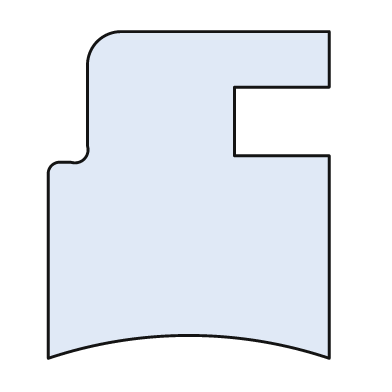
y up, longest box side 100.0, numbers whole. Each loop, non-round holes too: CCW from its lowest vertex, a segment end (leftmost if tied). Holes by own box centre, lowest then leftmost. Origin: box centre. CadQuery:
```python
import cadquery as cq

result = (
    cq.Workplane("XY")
    .moveTo(-43.0, -50.0)
    .threePointArc((0.0, -43.0), (43.0, -50.0))
    .lineTo(43.0, 12.0)
    .lineTo(14.0, 12.0)
    .lineTo(14.0, 33.0)
    .lineTo(43.0, 33.0)
    .lineTo(43.0, 50.0)
    .lineTo(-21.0, 50.0)
    .threePointArc((-28.0, 47.0), (-31.0, 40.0))
    .lineTo(-31.0, 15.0)
    .threePointArc((-32.0, 11.0), (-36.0, 10.0))
    .lineTo(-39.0, 10.0)
    .threePointArc((-42.0, 9.0), (-43.0, 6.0))
    .close()
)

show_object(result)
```